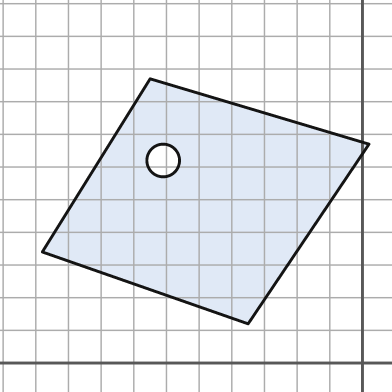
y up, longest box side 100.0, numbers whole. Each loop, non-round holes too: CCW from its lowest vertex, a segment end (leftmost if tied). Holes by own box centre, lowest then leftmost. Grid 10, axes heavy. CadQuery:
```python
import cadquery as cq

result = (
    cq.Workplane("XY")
    .moveTo(-35.0, 12.0)
    .lineTo(2.0, 67.0)
    .lineTo(-65.0, 87.0)
    .lineTo(-98.0, 34.0)
    .close()
    .moveTo(-61.0, 62.0)
    .circle(5.0)
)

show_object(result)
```